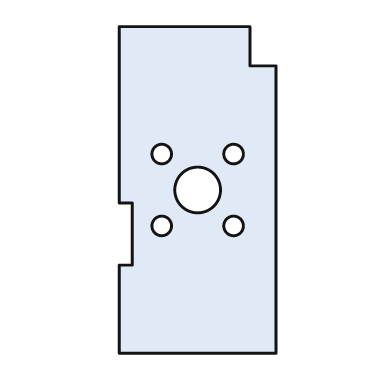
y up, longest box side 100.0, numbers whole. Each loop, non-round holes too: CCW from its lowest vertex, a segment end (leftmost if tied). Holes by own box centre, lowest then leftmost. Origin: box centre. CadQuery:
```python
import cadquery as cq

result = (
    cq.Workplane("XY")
    .moveTo(-24.0, -50.0)
    .lineTo(24.0, -50.0)
    .lineTo(24.0, 38.0)
    .lineTo(16.0, 38.0)
    .lineTo(16.0, 50.0)
    .lineTo(-24.0, 50.0)
    .lineTo(-24.0, -4.0)
    .lineTo(-20.0, -4.0)
    .lineTo(-20.0, -23.0)
    .lineTo(-24.0, -23.0)
    .close()
    .moveTo(-11.0, -11.0)
    .circle(3.0)
    .moveTo(11.0, -11.0)
    .circle(3.0)
    .moveTo(0.0, 0.0)
    .circle(7.0)
    .moveTo(-11.0, 11.0)
    .circle(3.0)
    .moveTo(11.0, 11.0)
    .circle(3.0)
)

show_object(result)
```